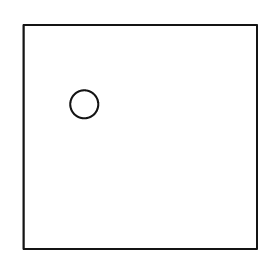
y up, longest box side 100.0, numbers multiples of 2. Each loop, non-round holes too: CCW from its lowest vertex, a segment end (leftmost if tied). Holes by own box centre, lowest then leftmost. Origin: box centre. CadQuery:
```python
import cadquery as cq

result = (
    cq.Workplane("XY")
    .moveTo(-50.0, -48.0)
    .lineTo(50.0, -48.0)
    .lineTo(50.0, 48.0)
    .lineTo(-50.0, 48.0)
    .close()
    .moveTo(-24.0, 14.0)
    .circle(6.0)
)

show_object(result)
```